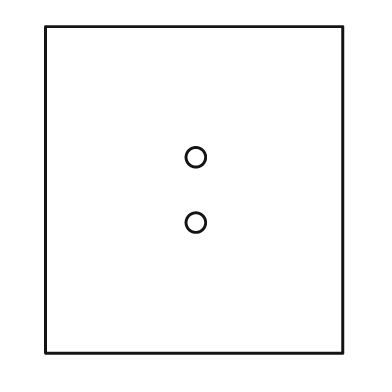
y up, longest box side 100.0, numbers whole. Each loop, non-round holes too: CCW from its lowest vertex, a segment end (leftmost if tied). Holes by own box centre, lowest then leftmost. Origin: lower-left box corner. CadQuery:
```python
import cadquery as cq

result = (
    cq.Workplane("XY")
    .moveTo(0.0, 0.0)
    .lineTo(91.0, 0.0)
    .lineTo(91.0, 100.0)
    .lineTo(0.0, 100.0)
    .close()
    .moveTo(46.0, 40.0)
    .circle(3.0)
    .moveTo(46.0, 60.0)
    .circle(3.0)
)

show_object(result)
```